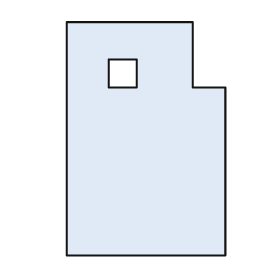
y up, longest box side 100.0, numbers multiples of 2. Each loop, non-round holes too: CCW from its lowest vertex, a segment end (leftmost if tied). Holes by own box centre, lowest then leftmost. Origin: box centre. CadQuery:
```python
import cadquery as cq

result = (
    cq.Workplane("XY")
    .moveTo(-34.0, -50.0)
    .lineTo(34.0, -50.0)
    .lineTo(34.0, 22.0)
    .lineTo(20.0, 22.0)
    .lineTo(20.0, 50.0)
    .lineTo(-34.0, 50.0)
    .close()
    .moveTo(-16.0, 22.0)
    .lineTo(-4.0, 22.0)
    .lineTo(-4.0, 34.0)
    .lineTo(-16.0, 34.0)
    .close()
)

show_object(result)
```